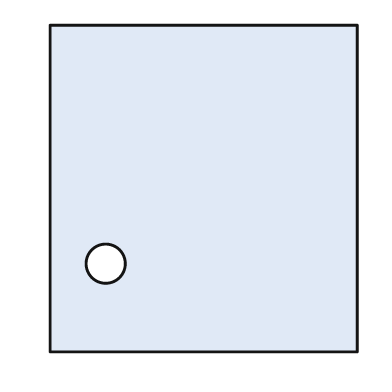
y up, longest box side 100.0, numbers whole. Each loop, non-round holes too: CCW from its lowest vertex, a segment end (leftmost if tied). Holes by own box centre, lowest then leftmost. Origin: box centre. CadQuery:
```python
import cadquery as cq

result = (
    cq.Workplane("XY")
    .moveTo(-47.0, -50.0)
    .lineTo(47.0, -50.0)
    .lineTo(47.0, 50.0)
    .lineTo(-47.0, 50.0)
    .close()
    .moveTo(-30.0, -23.0)
    .circle(6.0)
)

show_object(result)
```